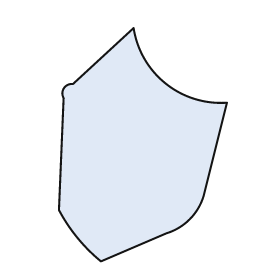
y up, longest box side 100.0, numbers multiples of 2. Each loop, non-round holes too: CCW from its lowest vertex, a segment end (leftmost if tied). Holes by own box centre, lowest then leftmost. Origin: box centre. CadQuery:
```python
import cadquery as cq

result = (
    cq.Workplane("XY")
    .moveTo(-18.0, -50.0)
    .lineTo(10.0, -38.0)
    .threePointArc((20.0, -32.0), (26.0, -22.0))
    .lineTo(36.0, 18.0)
    .threePointArc((10.0, 26.0), (-4.0, 50.0))
    .lineTo(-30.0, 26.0)
    .threePointArc((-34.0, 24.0), (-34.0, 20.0))
    .lineTo(-36.0, -28.0)
    .threePointArc((-28.0, -40.0), (-18.0, -50.0))
    .close()
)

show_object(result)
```